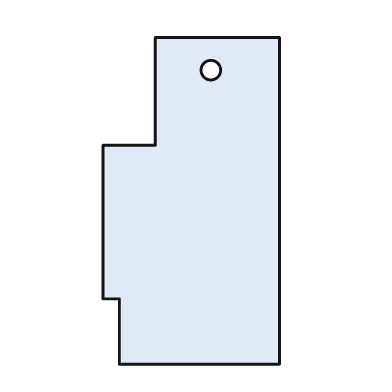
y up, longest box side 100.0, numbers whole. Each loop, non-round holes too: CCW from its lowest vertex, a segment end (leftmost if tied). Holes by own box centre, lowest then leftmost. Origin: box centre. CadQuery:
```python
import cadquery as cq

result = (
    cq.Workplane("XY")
    .moveTo(-22.0, -50.0)
    .lineTo(27.0, -50.0)
    .lineTo(27.0, 50.0)
    .lineTo(-11.0, 50.0)
    .lineTo(-11.0, 17.0)
    .lineTo(-27.0, 17.0)
    .lineTo(-27.0, -30.0)
    .lineTo(-22.0, -30.0)
    .close()
    .moveTo(6.0, 40.0)
    .circle(3.0)
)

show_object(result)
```